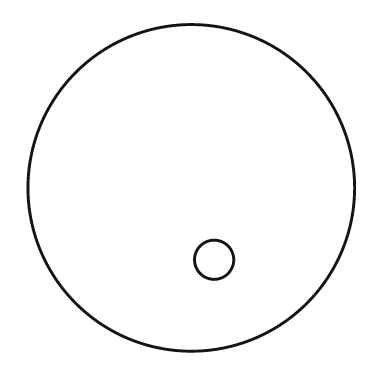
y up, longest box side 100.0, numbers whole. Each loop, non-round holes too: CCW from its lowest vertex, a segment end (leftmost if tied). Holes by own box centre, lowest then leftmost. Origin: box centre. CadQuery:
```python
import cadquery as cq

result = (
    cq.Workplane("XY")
    .moveTo(0.0, 0.0)
    .circle(50.0)
    .moveTo(7.0, -22.0)
    .circle(6.0)
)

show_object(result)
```